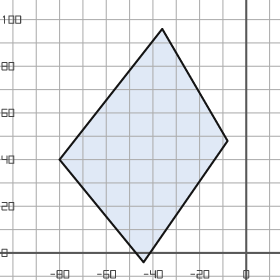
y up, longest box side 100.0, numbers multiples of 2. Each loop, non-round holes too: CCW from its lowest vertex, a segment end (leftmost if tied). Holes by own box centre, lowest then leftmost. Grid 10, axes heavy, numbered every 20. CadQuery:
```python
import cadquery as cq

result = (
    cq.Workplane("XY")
    .moveTo(-44.0, -4.0)
    .lineTo(-8.0, 48.0)
    .lineTo(-36.0, 96.0)
    .lineTo(-80.0, 40.0)
    .close()
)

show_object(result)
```